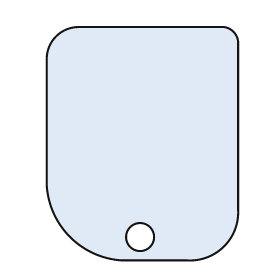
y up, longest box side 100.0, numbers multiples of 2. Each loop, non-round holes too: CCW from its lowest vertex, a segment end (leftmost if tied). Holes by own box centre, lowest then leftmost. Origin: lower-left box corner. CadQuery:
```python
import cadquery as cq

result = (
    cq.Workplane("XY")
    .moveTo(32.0, 0.0)
    .lineTo(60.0, 0.0)
    .threePointArc((76.0, 6.0), (82.0, 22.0))
    .lineTo(82.0, 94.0)
    .threePointArc((80.0, 98.0), (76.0, 100.0))
    .lineTo(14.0, 100.0)
    .threePointArc((4.0, 96.0), (0.0, 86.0))
    .lineTo(0.0, 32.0)
    .threePointArc((10.0, 10.0), (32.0, 0.0))
    .close()
    .moveTo(40.0, 10.0)
    .circle(6.0)
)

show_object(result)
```